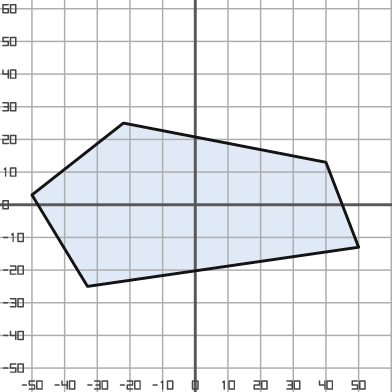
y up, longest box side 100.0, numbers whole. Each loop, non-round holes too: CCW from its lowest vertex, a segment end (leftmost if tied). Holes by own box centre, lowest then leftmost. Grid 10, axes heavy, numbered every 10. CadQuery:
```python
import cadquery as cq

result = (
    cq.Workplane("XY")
    .moveTo(-33.0, -25.0)
    .lineTo(50.0, -13.0)
    .lineTo(40.0, 13.0)
    .lineTo(-22.0, 25.0)
    .lineTo(-50.0, 3.0)
    .close()
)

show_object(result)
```